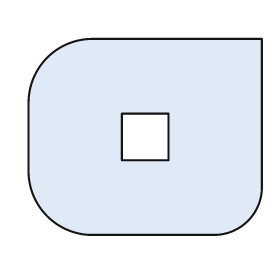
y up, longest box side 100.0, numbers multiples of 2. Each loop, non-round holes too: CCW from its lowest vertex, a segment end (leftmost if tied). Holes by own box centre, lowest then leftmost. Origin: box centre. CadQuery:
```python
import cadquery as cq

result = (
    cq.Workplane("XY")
    .moveTo(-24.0, -42.0)
    .lineTo(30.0, -42.0)
    .threePointArc((44.0, -36.0), (50.0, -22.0))
    .lineTo(50.0, 42.0)
    .lineTo(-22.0, 42.0)
    .threePointArc((-42.0, 34.0), (-50.0, 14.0))
    .lineTo(-50.0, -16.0)
    .threePointArc((-42.0, -34.0), (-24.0, -42.0))
    .close()
    .moveTo(-10.0, -10.0)
    .lineTo(10.0, -10.0)
    .lineTo(10.0, 10.0)
    .lineTo(-10.0, 10.0)
    .close()
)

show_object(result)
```